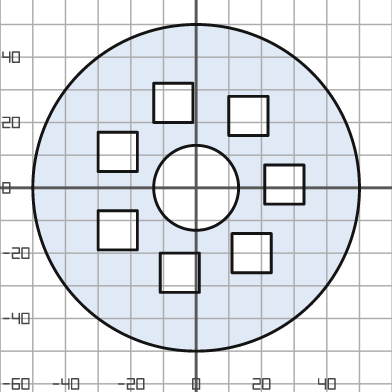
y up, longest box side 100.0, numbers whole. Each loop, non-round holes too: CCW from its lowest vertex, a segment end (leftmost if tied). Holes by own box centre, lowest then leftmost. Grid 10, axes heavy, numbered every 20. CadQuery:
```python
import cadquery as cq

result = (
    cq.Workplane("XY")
    .moveTo(0.0, 0.0)
    .circle(50.0)
    .moveTo(-11.0, -32.0)
    .lineTo(1.0, -32.0)
    .lineTo(1.0, -20.0)
    .lineTo(-11.0, -20.0)
    .close()
    .moveTo(11.0, -26.0)
    .lineTo(23.0, -26.0)
    .lineTo(23.0, -14.0)
    .lineTo(11.0, -14.0)
    .close()
    .moveTo(-30.0, -19.0)
    .lineTo(-18.0, -19.0)
    .lineTo(-18.0, -7.0)
    .lineTo(-30.0, -7.0)
    .close()
    .moveTo(0.0, 0.0)
    .circle(13.0)
    .moveTo(21.0, -5.0)
    .lineTo(33.0, -5.0)
    .lineTo(33.0, 7.0)
    .lineTo(21.0, 7.0)
    .close()
    .moveTo(-30.0, 5.0)
    .lineTo(-18.0, 5.0)
    .lineTo(-18.0, 17.0)
    .lineTo(-30.0, 17.0)
    .close()
    .moveTo(10.0, 16.0)
    .lineTo(22.0, 16.0)
    .lineTo(22.0, 28.0)
    .lineTo(10.0, 28.0)
    .close()
    .moveTo(-13.0, 20.0)
    .lineTo(-1.0, 20.0)
    .lineTo(-1.0, 32.0)
    .lineTo(-13.0, 32.0)
    .close()
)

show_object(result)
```